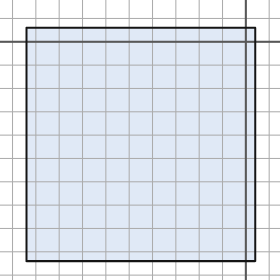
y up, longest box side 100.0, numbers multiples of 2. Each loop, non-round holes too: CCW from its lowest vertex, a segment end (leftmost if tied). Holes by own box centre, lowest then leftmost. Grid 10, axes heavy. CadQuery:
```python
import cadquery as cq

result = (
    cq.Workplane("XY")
    .moveTo(-94.0, -94.0)
    .lineTo(4.0, -94.0)
    .lineTo(4.0, 6.0)
    .lineTo(-94.0, 6.0)
    .close()
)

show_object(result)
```